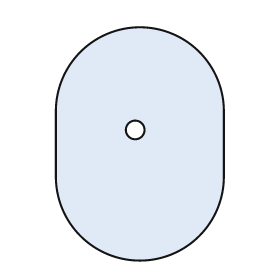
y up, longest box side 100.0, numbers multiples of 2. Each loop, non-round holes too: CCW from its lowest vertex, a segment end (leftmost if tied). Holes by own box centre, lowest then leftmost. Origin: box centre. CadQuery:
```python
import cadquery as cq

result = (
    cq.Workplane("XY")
    .moveTo(-36.0, -14.0)
    .threePointArc((0.0, -50.0), (36.0, -14.0))
    .lineTo(36.0, 14.0)
    .threePointArc((0.0, 50.0), (-36.0, 14.0))
    .close()
    .moveTo(-2.0, 6.0)
    .circle(4.0)
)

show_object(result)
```